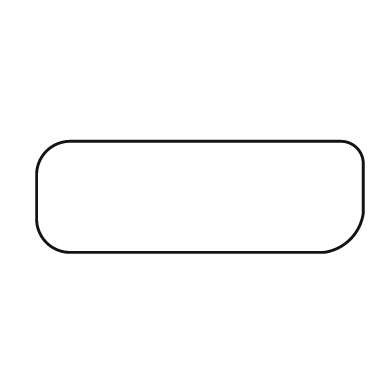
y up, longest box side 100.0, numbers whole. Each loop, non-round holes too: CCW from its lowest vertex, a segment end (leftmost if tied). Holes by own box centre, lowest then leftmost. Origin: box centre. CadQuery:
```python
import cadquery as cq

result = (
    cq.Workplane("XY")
    .moveTo(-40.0, -17.0)
    .lineTo(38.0, -17.0)
    .threePointArc((46.0, -13.0), (50.0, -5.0))
    .lineTo(50.0, 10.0)
    .threePointArc((48.0, 15.0), (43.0, 17.0))
    .lineTo(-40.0, 17.0)
    .threePointArc((-47.0, 14.0), (-50.0, 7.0))
    .lineTo(-50.0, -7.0)
    .threePointArc((-47.0, -14.0), (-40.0, -17.0))
    .close()
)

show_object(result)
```